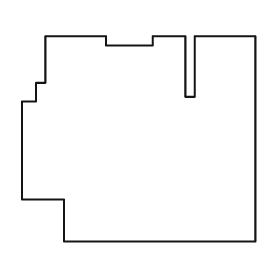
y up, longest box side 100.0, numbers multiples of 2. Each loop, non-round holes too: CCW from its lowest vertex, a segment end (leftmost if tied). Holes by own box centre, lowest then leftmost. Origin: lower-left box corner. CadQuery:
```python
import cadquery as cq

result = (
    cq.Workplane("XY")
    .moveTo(18.0, 0.0)
    .lineTo(100.0, 0.0)
    .lineTo(100.0, 88.0)
    .lineTo(74.0, 88.0)
    .lineTo(74.0, 62.0)
    .lineTo(70.0, 62.0)
    .lineTo(70.0, 88.0)
    .lineTo(56.0, 88.0)
    .lineTo(56.0, 84.0)
    .lineTo(36.0, 84.0)
    .lineTo(36.0, 88.0)
    .lineTo(10.0, 88.0)
    .lineTo(10.0, 68.0)
    .lineTo(6.0, 68.0)
    .lineTo(6.0, 60.0)
    .lineTo(0.0, 60.0)
    .lineTo(0.0, 18.0)
    .lineTo(18.0, 18.0)
    .close()
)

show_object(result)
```